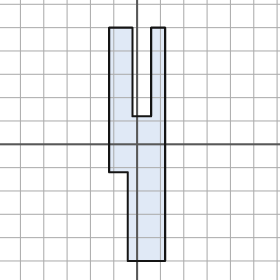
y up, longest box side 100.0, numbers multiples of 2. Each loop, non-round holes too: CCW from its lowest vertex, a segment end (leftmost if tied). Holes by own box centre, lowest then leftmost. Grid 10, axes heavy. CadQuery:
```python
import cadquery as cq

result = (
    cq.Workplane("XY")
    .moveTo(-4.0, -50.0)
    .lineTo(12.0, -50.0)
    .lineTo(12.0, 50.0)
    .lineTo(6.0, 50.0)
    .lineTo(6.0, 12.0)
    .lineTo(-2.0, 12.0)
    .lineTo(-2.0, 50.0)
    .lineTo(-12.0, 50.0)
    .lineTo(-12.0, -12.0)
    .lineTo(-4.0, -12.0)
    .close()
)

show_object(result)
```